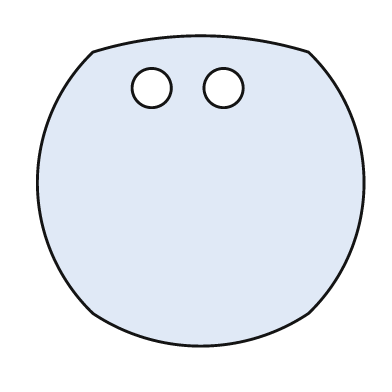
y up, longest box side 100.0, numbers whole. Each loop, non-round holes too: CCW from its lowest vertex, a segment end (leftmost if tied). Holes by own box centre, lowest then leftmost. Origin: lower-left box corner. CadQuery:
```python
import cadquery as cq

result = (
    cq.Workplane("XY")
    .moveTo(17.0, 10.0)
    .threePointArc((50.0, 0.0), (83.0, 10.0))
    .threePointArc((100.0, 50.0), (83.0, 90.0))
    .threePointArc((50.0, 95.0), (17.0, 90.0))
    .threePointArc((0.0, 50.0), (17.0, 10.0))
    .close()
    .moveTo(35.0, 79.0)
    .circle(6.0)
    .moveTo(57.0, 79.0)
    .circle(6.0)
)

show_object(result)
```